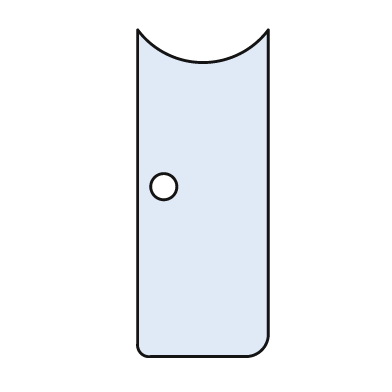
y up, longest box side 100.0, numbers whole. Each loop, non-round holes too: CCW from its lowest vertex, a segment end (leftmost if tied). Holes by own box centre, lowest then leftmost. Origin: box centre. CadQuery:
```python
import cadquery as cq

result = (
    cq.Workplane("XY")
    .moveTo(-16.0, -50.0)
    .lineTo(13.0, -50.0)
    .threePointArc((18.0, -48.0), (20.0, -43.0))
    .lineTo(20.0, 50.0)
    .threePointArc((0.0, 40.0), (-20.0, 50.0))
    .lineTo(-20.0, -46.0)
    .threePointArc((-19.0, -49.0), (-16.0, -50.0))
    .close()
    .moveTo(-12.0, 2.0)
    .circle(4.0)
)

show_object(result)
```